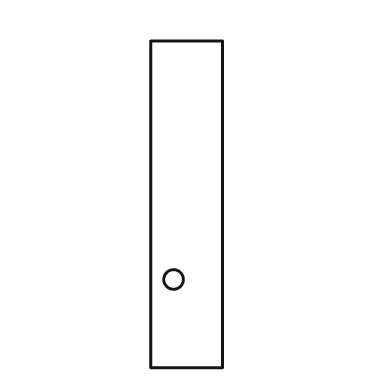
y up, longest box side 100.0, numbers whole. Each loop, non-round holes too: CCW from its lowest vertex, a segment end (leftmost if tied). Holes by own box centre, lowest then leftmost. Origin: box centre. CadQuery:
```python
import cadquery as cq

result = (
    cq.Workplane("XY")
    .moveTo(-11.0, -50.0)
    .lineTo(11.0, -50.0)
    .lineTo(11.0, 50.0)
    .lineTo(-11.0, 50.0)
    .close()
    .moveTo(-4.0, -23.0)
    .circle(3.0)
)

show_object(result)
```